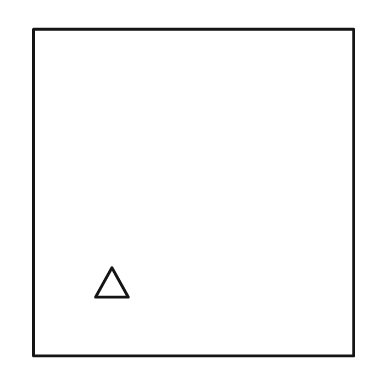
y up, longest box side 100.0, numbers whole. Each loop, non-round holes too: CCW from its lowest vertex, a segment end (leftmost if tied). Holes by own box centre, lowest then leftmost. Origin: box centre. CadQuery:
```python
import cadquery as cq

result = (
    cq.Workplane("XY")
    .moveTo(-49.0, -50.0)
    .lineTo(49.0, -50.0)
    .lineTo(49.0, 50.0)
    .lineTo(-49.0, 50.0)
    .close()
    .moveTo(-30.0, -32.0)
    .lineTo(-20.0, -32.0)
    .lineTo(-25.0, -23.0)
    .close()
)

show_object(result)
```